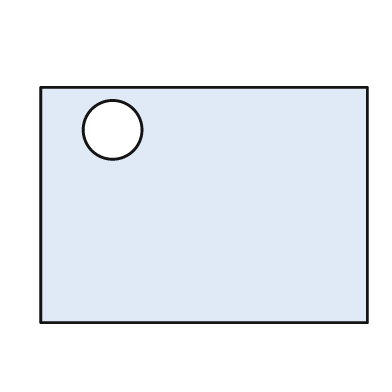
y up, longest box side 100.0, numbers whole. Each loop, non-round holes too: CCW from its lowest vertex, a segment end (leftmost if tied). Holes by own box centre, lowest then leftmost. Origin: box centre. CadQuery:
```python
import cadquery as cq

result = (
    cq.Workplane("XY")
    .moveTo(-50.0, -36.0)
    .lineTo(50.0, -36.0)
    .lineTo(50.0, 36.0)
    .lineTo(-50.0, 36.0)
    .close()
    .moveTo(-28.0, 23.0)
    .circle(9.0)
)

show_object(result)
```